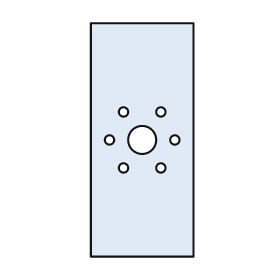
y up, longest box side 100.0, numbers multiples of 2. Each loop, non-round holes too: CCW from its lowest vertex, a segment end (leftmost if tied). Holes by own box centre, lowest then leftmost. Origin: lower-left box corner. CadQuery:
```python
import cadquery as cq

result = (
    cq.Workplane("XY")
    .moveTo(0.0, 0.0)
    .lineTo(44.0, 0.0)
    .lineTo(44.0, 100.0)
    .lineTo(0.0, 100.0)
    .close()
    .moveTo(14.0, 38.0)
    .circle(2.0)
    .moveTo(30.0, 38.0)
    .circle(2.0)
    .moveTo(8.0, 50.0)
    .circle(2.0)
    .moveTo(22.0, 50.0)
    .circle(6.0)
    .moveTo(36.0, 50.0)
    .circle(2.0)
    .moveTo(14.0, 62.0)
    .circle(2.0)
    .moveTo(30.0, 62.0)
    .circle(2.0)
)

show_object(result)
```